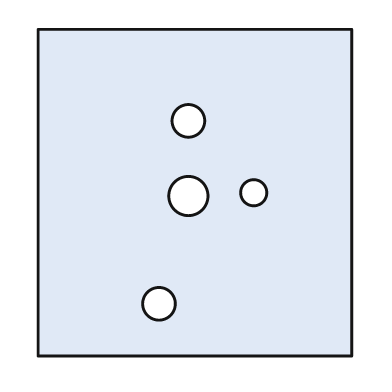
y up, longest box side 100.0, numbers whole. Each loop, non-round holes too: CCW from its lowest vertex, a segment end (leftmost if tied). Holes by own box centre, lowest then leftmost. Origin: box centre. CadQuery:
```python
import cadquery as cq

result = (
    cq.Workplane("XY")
    .moveTo(-48.0, -50.0)
    .lineTo(48.0, -50.0)
    .lineTo(48.0, 50.0)
    .lineTo(-48.0, 50.0)
    .close()
    .moveTo(-11.0, -34.0)
    .circle(5.0)
    .moveTo(-2.0, -1.0)
    .circle(6.0)
    .moveTo(18.0, 0.0)
    .circle(4.0)
    .moveTo(-2.0, 22.0)
    .circle(5.0)
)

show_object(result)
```